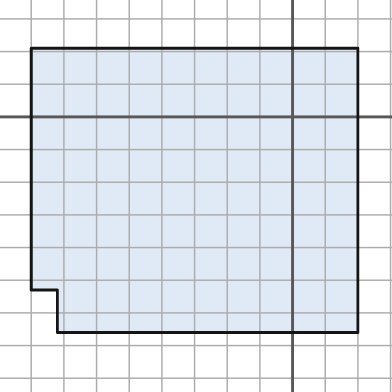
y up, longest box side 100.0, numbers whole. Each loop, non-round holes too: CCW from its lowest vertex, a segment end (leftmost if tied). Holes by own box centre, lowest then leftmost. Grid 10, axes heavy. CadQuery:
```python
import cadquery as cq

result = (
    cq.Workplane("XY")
    .moveTo(-72.0, -66.0)
    .lineTo(20.0, -66.0)
    .lineTo(20.0, 21.0)
    .lineTo(-80.0, 21.0)
    .lineTo(-80.0, -53.0)
    .lineTo(-72.0, -53.0)
    .close()
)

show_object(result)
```